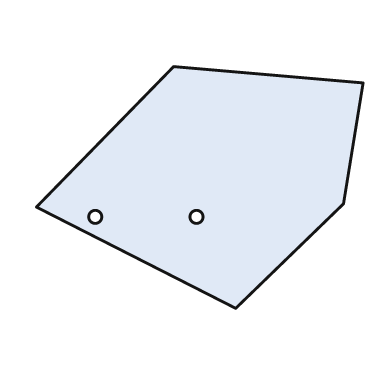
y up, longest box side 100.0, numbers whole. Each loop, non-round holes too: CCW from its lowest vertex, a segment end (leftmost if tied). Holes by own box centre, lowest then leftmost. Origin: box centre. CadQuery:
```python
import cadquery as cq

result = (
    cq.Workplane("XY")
    .moveTo(11.0, -37.0)
    .lineTo(44.0, -5.0)
    .lineTo(50.0, 32.0)
    .lineTo(-8.0, 37.0)
    .lineTo(-50.0, -6.0)
    .close()
    .moveTo(-32.0, -9.0)
    .circle(2.0)
    .moveTo(-1.0, -9.0)
    .circle(2.0)
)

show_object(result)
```